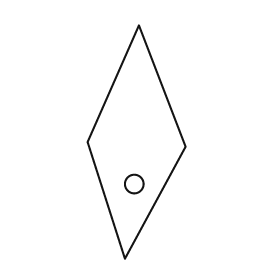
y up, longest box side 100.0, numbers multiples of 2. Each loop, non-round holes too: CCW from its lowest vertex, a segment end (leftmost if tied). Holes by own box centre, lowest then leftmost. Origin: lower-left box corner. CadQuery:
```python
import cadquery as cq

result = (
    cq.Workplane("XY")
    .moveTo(16.0, 0.0)
    .lineTo(42.0, 48.0)
    .lineTo(22.0, 100.0)
    .lineTo(0.0, 50.0)
    .close()
    .moveTo(20.0, 32.0)
    .circle(4.0)
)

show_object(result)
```